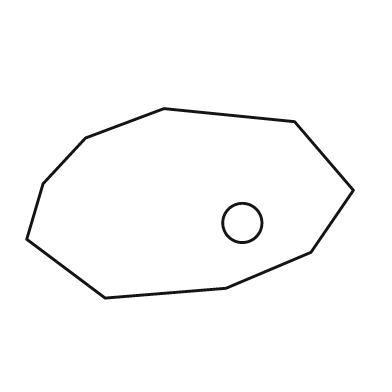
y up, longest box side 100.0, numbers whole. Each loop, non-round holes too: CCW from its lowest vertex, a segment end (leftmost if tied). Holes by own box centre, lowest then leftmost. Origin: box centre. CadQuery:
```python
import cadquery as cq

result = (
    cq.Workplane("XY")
    .moveTo(-26.0, -29.0)
    .lineTo(11.0, -26.0)
    .lineTo(37.0, -15.0)
    .lineTo(50.0, 4.0)
    .lineTo(32.0, 25.0)
    .lineTo(-8.0, 29.0)
    .lineTo(-32.0, 20.0)
    .lineTo(-45.0, 6.0)
    .lineTo(-50.0, -11.0)
    .close()
    .moveTo(16.0, -6.0)
    .circle(6.0)
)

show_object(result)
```